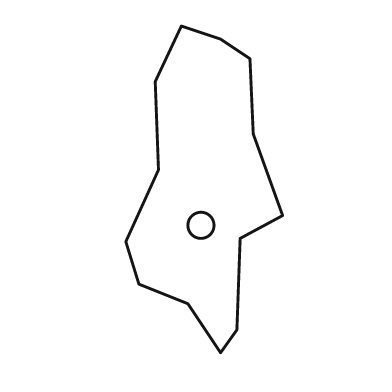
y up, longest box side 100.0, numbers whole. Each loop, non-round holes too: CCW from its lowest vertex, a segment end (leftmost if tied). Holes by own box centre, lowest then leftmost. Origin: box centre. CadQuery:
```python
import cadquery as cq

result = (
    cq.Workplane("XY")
    .moveTo(5.0, -50.0)
    .lineTo(10.0, -43.0)
    .lineTo(11.0, -15.0)
    .lineTo(24.0, -8.0)
    .lineTo(15.0, 17.0)
    .lineTo(14.0, 40.0)
    .lineTo(5.0, 46.0)
    .lineTo(-7.0, 50.0)
    .lineTo(-15.0, 33.0)
    .lineTo(-14.0, 6.0)
    .lineTo(-24.0, -16.0)
    .lineTo(-20.0, -29.0)
    .lineTo(-5.0, -35.0)
    .close()
    .moveTo(-1.0, -11.0)
    .circle(4.0)
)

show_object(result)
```